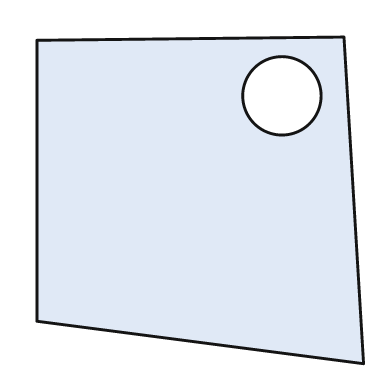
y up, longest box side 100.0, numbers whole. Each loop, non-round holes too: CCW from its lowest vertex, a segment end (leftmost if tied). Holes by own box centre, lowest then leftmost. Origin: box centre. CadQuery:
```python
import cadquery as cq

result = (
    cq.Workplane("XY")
    .moveTo(50.0, -50.0)
    .lineTo(44.0, 50.0)
    .lineTo(-50.0, 49.0)
    .lineTo(-50.0, -37.0)
    .close()
    .moveTo(25.0, 32.0)
    .circle(12.0)
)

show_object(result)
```